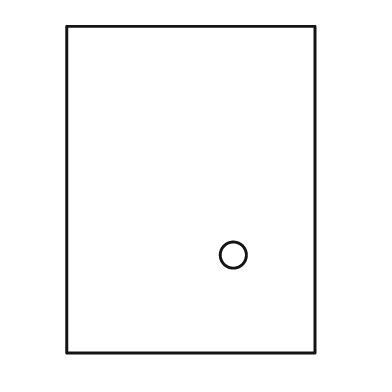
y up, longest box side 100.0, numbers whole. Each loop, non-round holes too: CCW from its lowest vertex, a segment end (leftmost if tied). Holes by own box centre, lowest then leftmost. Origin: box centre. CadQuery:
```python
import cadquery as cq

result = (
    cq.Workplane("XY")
    .moveTo(-38.0, -50.0)
    .lineTo(38.0, -50.0)
    .lineTo(38.0, 50.0)
    .lineTo(-38.0, 50.0)
    .close()
    .moveTo(13.0, -20.0)
    .circle(4.0)
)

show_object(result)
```